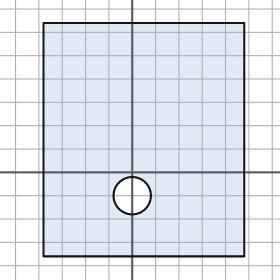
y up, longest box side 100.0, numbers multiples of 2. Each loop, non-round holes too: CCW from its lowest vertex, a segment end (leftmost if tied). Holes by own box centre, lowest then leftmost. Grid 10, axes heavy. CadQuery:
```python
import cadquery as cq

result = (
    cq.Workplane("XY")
    .moveTo(-38.0, -36.0)
    .lineTo(48.0, -36.0)
    .lineTo(48.0, 64.0)
    .lineTo(-38.0, 64.0)
    .close()
    .moveTo(0.0, -10.0)
    .circle(8.0)
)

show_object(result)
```